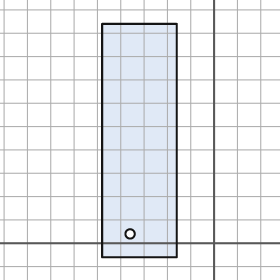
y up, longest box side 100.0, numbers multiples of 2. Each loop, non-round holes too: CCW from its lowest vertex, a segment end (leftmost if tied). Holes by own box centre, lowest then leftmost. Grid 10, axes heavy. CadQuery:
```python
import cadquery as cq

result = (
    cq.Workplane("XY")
    .moveTo(-48.0, -6.0)
    .lineTo(-16.0, -6.0)
    .lineTo(-16.0, 94.0)
    .lineTo(-48.0, 94.0)
    .close()
    .moveTo(-36.0, 4.0)
    .circle(2.0)
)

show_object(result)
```